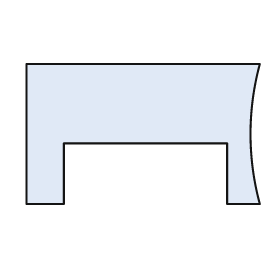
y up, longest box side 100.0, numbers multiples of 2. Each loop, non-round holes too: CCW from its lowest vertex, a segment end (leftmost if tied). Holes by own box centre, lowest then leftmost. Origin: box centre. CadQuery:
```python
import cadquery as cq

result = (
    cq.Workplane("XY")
    .moveTo(-50.0, -30.0)
    .lineTo(-34.0, -30.0)
    .lineTo(-34.0, -4.0)
    .lineTo(36.0, -4.0)
    .lineTo(36.0, -30.0)
    .lineTo(50.0, -30.0)
    .threePointArc((46.0, 0.0), (50.0, 30.0))
    .lineTo(-50.0, 30.0)
    .close()
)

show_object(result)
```